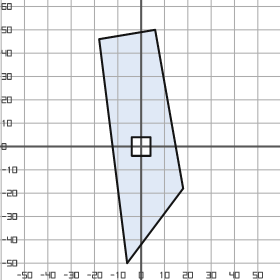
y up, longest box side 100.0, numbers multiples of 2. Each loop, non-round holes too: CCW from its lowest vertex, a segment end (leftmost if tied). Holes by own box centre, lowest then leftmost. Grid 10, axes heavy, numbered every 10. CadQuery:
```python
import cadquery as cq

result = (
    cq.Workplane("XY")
    .moveTo(-6.0, -50.0)
    .lineTo(18.0, -18.0)
    .lineTo(6.0, 50.0)
    .lineTo(-18.0, 46.0)
    .close()
    .moveTo(-4.0, -4.0)
    .lineTo(4.0, -4.0)
    .lineTo(4.0, 4.0)
    .lineTo(-4.0, 4.0)
    .close()
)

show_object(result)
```